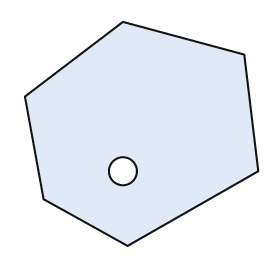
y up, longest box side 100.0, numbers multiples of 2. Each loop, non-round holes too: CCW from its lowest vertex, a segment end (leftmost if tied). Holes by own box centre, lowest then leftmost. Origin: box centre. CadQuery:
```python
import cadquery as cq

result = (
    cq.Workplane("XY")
    .moveTo(-6.0, -48.0)
    .lineTo(50.0, -16.0)
    .lineTo(44.0, 34.0)
    .lineTo(-8.0, 48.0)
    .lineTo(-50.0, 16.0)
    .lineTo(-42.0, -28.0)
    .close()
    .moveTo(-8.0, -16.0)
    .circle(6.0)
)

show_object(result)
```